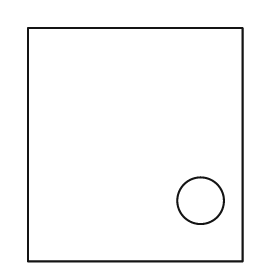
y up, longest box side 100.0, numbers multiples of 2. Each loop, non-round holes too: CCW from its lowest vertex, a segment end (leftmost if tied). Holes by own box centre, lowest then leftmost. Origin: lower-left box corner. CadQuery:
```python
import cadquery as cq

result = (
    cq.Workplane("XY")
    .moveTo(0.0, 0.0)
    .lineTo(92.0, 0.0)
    .lineTo(92.0, 100.0)
    .lineTo(0.0, 100.0)
    .close()
    .moveTo(74.0, 26.0)
    .circle(10.0)
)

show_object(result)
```